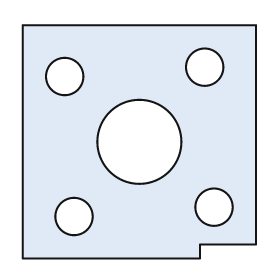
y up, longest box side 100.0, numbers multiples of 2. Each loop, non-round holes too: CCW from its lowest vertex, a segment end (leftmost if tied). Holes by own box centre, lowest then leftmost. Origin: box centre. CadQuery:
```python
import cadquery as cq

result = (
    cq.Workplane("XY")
    .moveTo(-50.0, -50.0)
    .lineTo(26.0, -50.0)
    .lineTo(26.0, -44.0)
    .lineTo(50.0, -44.0)
    .lineTo(50.0, 50.0)
    .lineTo(-50.0, 50.0)
    .close()
    .moveTo(-28.0, -32.0)
    .circle(8.0)
    .moveTo(32.0, -28.0)
    .circle(8.0)
    .moveTo(0.0, 0.0)
    .circle(18.0)
    .moveTo(-32.0, 28.0)
    .circle(8.0)
    .moveTo(28.0, 32.0)
    .circle(8.0)
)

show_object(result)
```